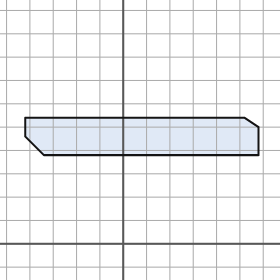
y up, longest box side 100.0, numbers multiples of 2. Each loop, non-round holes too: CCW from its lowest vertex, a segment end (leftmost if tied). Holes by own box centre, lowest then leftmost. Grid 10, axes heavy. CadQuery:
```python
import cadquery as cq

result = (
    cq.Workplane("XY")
    .moveTo(-34.0, 38.0)
    .lineTo(58.0, 38.0)
    .lineTo(58.0, 50.0)
    .lineTo(52.0, 54.0)
    .lineTo(-42.0, 54.0)
    .lineTo(-42.0, 46.0)
    .close()
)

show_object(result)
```